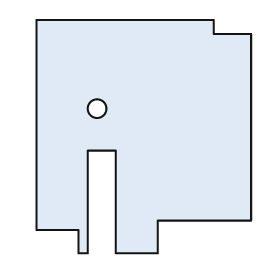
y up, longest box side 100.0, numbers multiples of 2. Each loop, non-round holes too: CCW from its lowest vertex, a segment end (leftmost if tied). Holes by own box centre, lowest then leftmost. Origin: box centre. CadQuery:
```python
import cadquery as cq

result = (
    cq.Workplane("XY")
    .moveTo(-28.0, -50.0)
    .lineTo(-24.0, -50.0)
    .lineTo(-24.0, -6.0)
    .lineTo(-12.0, -6.0)
    .lineTo(-12.0, -50.0)
    .lineTo(6.0, -50.0)
    .lineTo(6.0, -36.0)
    .lineTo(46.0, -36.0)
    .lineTo(46.0, 44.0)
    .lineTo(30.0, 44.0)
    .lineTo(30.0, 50.0)
    .lineTo(-46.0, 50.0)
    .lineTo(-46.0, -40.0)
    .lineTo(-28.0, -40.0)
    .close()
    .moveTo(-20.0, 12.0)
    .circle(4.0)
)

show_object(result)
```